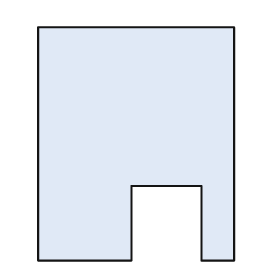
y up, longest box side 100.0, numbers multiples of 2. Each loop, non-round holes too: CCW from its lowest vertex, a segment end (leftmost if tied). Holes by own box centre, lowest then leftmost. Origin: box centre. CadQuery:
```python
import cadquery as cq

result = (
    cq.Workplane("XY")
    .moveTo(-42.0, -50.0)
    .lineTo(-2.0, -50.0)
    .lineTo(-2.0, -18.0)
    .lineTo(28.0, -18.0)
    .lineTo(28.0, -50.0)
    .lineTo(42.0, -50.0)
    .lineTo(42.0, 50.0)
    .lineTo(-42.0, 50.0)
    .close()
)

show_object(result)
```